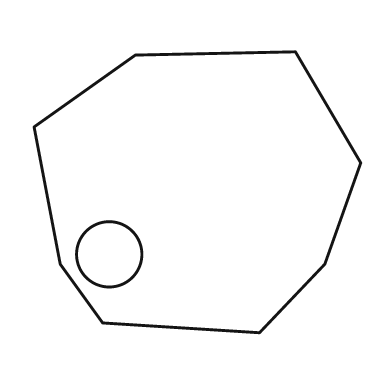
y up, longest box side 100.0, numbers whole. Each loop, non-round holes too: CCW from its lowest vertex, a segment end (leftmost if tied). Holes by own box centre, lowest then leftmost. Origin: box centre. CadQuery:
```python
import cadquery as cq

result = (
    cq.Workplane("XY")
    .moveTo(19.0, -43.0)
    .lineTo(39.0, -22.0)
    .lineTo(50.0, 9.0)
    .lineTo(30.0, 43.0)
    .lineTo(-19.0, 42.0)
    .lineTo(-50.0, 20.0)
    .lineTo(-42.0, -22.0)
    .lineTo(-29.0, -40.0)
    .close()
    .moveTo(-27.0, -19.0)
    .circle(10.0)
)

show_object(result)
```